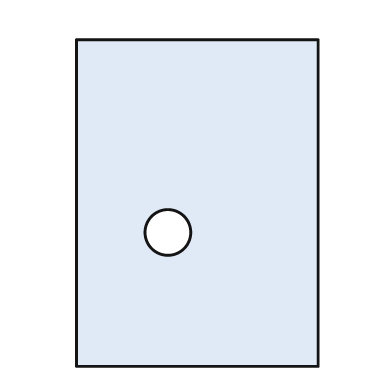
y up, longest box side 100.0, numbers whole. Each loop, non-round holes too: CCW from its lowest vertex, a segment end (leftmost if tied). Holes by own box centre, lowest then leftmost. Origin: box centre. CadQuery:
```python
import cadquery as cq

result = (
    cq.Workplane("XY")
    .moveTo(-37.0, -50.0)
    .lineTo(37.0, -50.0)
    .lineTo(37.0, 50.0)
    .lineTo(-37.0, 50.0)
    .close()
    .moveTo(-9.0, -9.0)
    .circle(7.0)
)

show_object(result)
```